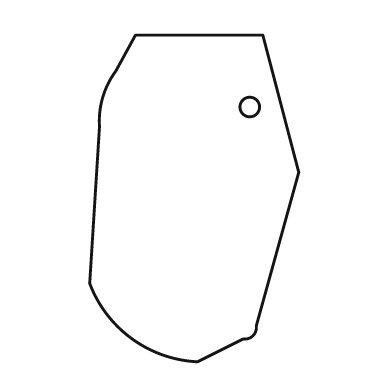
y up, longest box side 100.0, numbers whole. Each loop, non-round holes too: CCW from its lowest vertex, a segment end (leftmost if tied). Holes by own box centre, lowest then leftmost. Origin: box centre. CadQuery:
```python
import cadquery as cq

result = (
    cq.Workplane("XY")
    .moveTo(1.0, -50.0)
    .lineTo(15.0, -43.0)
    .threePointArc((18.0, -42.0), (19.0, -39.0))
    .lineTo(32.0, 8.0)
    .lineTo(21.0, 50.0)
    .lineTo(-18.0, 50.0)
    .lineTo(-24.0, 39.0)
    .threePointArc((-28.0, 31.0), (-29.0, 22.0))
    .lineTo(-32.0, -26.0)
    .threePointArc((-19.0, -43.0), (1.0, -50.0))
    .close()
    .moveTo(17.0, 28.0)
    .circle(3.0)
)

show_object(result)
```